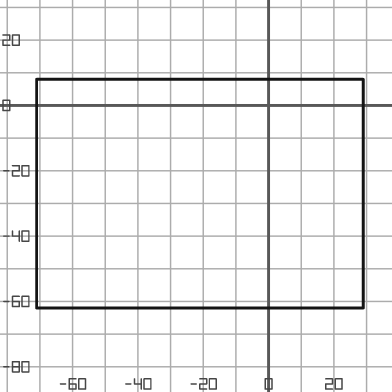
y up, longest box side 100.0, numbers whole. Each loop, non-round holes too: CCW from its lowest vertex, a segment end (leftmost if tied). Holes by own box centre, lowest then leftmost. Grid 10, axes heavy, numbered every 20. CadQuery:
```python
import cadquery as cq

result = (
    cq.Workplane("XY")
    .moveTo(-71.0, -62.0)
    .lineTo(29.0, -62.0)
    .lineTo(29.0, 8.0)
    .lineTo(-71.0, 8.0)
    .close()
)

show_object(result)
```